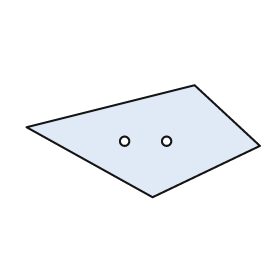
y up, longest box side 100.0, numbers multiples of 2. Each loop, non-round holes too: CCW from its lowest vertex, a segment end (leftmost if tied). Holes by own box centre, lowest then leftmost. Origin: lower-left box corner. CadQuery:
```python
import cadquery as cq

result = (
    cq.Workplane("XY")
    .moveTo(54.0, 0.0)
    .lineTo(100.0, 22.0)
    .lineTo(72.0, 48.0)
    .lineTo(0.0, 30.0)
    .close()
    .moveTo(42.0, 24.0)
    .circle(2.0)
    .moveTo(60.0, 24.0)
    .circle(2.0)
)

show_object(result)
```